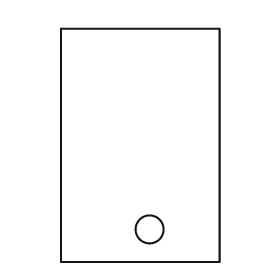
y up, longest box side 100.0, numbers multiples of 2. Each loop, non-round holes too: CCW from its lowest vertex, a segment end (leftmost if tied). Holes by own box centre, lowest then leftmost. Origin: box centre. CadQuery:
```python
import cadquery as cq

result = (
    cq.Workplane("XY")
    .moveTo(-34.0, -50.0)
    .lineTo(34.0, -50.0)
    .lineTo(34.0, 50.0)
    .lineTo(-34.0, 50.0)
    .close()
    .moveTo(4.0, -36.0)
    .circle(6.0)
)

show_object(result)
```